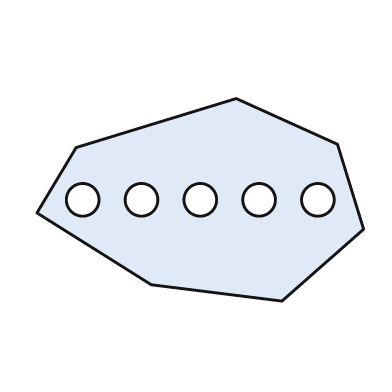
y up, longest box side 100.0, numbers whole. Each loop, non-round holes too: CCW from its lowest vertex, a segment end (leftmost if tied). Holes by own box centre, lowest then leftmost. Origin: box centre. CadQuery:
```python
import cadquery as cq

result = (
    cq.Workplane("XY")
    .moveTo(25.0, -31.0)
    .lineTo(50.0, -9.0)
    .lineTo(42.0, 17.0)
    .lineTo(11.0, 31.0)
    .lineTo(-38.0, 16.0)
    .lineTo(-50.0, -4.0)
    .lineTo(-15.0, -26.0)
    .close()
    .moveTo(-36.0, 0.0)
    .circle(5.0)
    .moveTo(-18.0, 0.0)
    .circle(5.0)
    .moveTo(0.0, 0.0)
    .circle(5.0)
    .moveTo(18.0, 0.0)
    .circle(5.0)
    .moveTo(36.0, 0.0)
    .circle(5.0)
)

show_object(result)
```